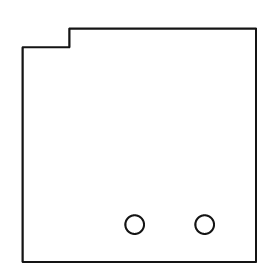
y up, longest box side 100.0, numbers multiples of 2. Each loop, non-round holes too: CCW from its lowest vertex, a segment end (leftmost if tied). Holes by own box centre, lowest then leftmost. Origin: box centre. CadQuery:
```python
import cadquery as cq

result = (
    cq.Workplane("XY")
    .moveTo(-50.0, -50.0)
    .lineTo(50.0, -50.0)
    .lineTo(50.0, 50.0)
    .lineTo(-30.0, 50.0)
    .lineTo(-30.0, 42.0)
    .lineTo(-50.0, 42.0)
    .close()
    .moveTo(-2.0, -34.0)
    .circle(4.0)
    .moveTo(28.0, -34.0)
    .circle(4.0)
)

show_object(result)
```